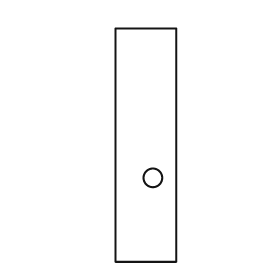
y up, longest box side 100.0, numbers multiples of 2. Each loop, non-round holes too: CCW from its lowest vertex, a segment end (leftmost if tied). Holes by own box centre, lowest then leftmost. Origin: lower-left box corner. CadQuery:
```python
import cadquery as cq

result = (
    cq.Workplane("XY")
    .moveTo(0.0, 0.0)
    .lineTo(26.0, 0.0)
    .lineTo(26.0, 100.0)
    .lineTo(0.0, 100.0)
    .close()
    .moveTo(16.0, 36.0)
    .circle(4.0)
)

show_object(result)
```